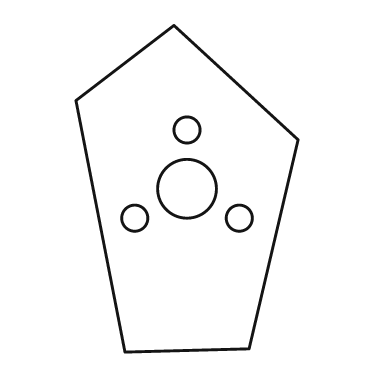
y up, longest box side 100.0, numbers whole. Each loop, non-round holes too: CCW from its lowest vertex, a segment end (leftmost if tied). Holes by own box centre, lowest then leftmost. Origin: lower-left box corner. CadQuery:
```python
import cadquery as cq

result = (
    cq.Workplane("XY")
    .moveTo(15.0, 0.0)
    .lineTo(53.0, 1.0)
    .lineTo(68.0, 65.0)
    .lineTo(30.0, 100.0)
    .lineTo(0.0, 77.0)
    .close()
    .moveTo(18.0, 41.0)
    .circle(4.0)
    .moveTo(50.0, 41.0)
    .circle(4.0)
    .moveTo(34.0, 50.0)
    .circle(9.0)
    .moveTo(34.0, 68.0)
    .circle(4.0)
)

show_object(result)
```